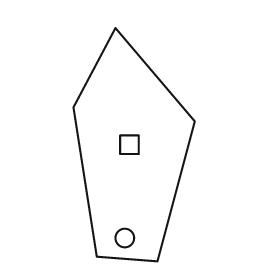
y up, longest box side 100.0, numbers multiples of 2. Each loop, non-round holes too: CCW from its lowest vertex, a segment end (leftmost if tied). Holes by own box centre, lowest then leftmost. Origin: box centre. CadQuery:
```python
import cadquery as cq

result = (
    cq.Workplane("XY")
    .moveTo(10.0, -50.0)
    .lineTo(26.0, 10.0)
    .lineTo(-8.0, 50.0)
    .lineTo(-26.0, 16.0)
    .lineTo(-16.0, -48.0)
    .close()
    .moveTo(-4.0, -40.0)
    .circle(4.0)
    .moveTo(-6.0, -4.0)
    .lineTo(2.0, -4.0)
    .lineTo(2.0, 4.0)
    .lineTo(-6.0, 4.0)
    .close()
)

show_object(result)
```